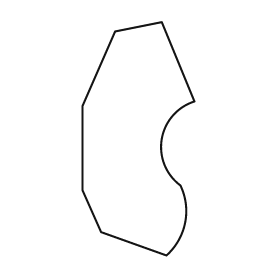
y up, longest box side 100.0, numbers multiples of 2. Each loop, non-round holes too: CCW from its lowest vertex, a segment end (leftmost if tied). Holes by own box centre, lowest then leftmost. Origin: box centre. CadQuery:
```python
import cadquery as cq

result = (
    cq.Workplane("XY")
    .moveTo(12.0, -50.0)
    .threePointArc((20.0, -36.0), (18.0, -20.0))
    .threePointArc((10.0, 0.0), (24.0, 16.0))
    .lineTo(10.0, 50.0)
    .lineTo(-10.0, 46.0)
    .lineTo(-24.0, 14.0)
    .lineTo(-24.0, -22.0)
    .lineTo(-16.0, -40.0)
    .close()
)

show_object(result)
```